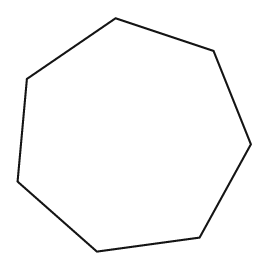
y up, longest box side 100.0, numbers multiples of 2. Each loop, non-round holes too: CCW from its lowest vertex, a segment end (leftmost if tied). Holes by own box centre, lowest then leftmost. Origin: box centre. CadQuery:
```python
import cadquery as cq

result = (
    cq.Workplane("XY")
    .moveTo(-16.0, -50.0)
    .lineTo(28.0, -44.0)
    .lineTo(50.0, -4.0)
    .lineTo(34.0, 36.0)
    .lineTo(-8.0, 50.0)
    .lineTo(-46.0, 24.0)
    .lineTo(-50.0, -20.0)
    .close()
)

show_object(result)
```